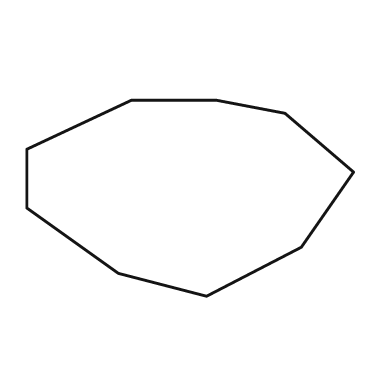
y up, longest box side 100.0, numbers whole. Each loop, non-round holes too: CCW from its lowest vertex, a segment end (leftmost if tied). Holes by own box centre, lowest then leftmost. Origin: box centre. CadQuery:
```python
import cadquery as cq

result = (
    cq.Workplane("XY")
    .moveTo(5.0, -30.0)
    .lineTo(34.0, -15.0)
    .lineTo(50.0, 8.0)
    .lineTo(29.0, 26.0)
    .lineTo(8.0, 30.0)
    .lineTo(-18.0, 30.0)
    .lineTo(-50.0, 15.0)
    .lineTo(-50.0, -3.0)
    .lineTo(-22.0, -23.0)
    .close()
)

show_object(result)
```